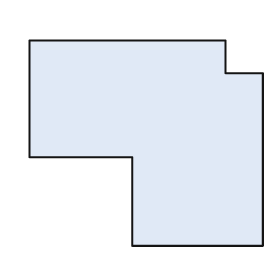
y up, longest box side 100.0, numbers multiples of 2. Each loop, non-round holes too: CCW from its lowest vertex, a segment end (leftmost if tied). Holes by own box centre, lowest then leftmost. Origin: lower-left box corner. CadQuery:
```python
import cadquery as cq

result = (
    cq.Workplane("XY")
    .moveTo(44.0, 0.0)
    .lineTo(100.0, 0.0)
    .lineTo(100.0, 74.0)
    .lineTo(84.0, 74.0)
    .lineTo(84.0, 88.0)
    .lineTo(0.0, 88.0)
    .lineTo(0.0, 38.0)
    .lineTo(44.0, 38.0)
    .close()
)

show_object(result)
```